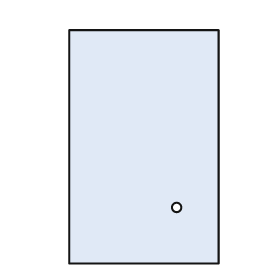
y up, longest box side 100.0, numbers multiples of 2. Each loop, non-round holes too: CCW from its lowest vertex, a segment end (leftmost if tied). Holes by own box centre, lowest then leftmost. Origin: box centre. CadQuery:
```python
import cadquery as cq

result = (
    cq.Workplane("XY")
    .moveTo(-32.0, -50.0)
    .lineTo(32.0, -50.0)
    .lineTo(32.0, 50.0)
    .lineTo(-32.0, 50.0)
    .close()
    .moveTo(14.0, -26.0)
    .circle(2.0)
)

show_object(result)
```